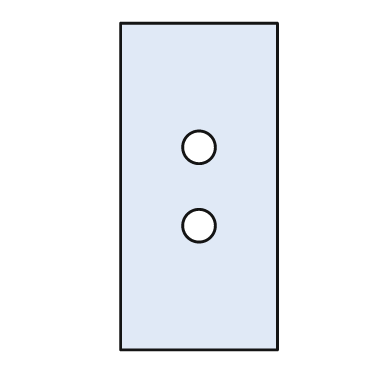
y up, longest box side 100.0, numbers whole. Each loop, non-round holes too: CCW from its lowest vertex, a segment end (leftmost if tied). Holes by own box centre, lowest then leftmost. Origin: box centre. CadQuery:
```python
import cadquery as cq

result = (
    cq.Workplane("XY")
    .moveTo(-24.0, -50.0)
    .lineTo(24.0, -50.0)
    .lineTo(24.0, 50.0)
    .lineTo(-24.0, 50.0)
    .close()
    .moveTo(0.0, -12.0)
    .circle(5.0)
    .moveTo(0.0, 12.0)
    .circle(5.0)
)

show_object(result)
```